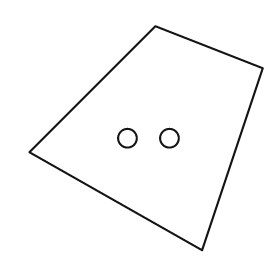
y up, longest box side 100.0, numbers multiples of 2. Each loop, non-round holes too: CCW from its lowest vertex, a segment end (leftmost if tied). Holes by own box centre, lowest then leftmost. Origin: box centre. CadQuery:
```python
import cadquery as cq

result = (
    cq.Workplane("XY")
    .moveTo(24.0, -48.0)
    .lineTo(50.0, 30.0)
    .lineTo(4.0, 48.0)
    .lineTo(-50.0, -6.0)
    .close()
    .moveTo(-8.0, 0.0)
    .circle(4.0)
    .moveTo(10.0, 0.0)
    .circle(4.0)
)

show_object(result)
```